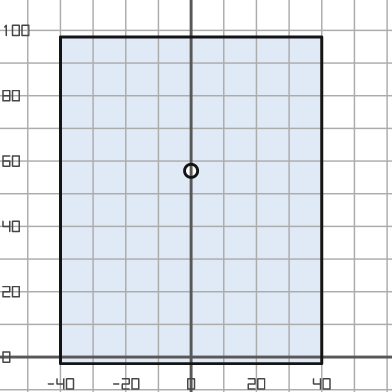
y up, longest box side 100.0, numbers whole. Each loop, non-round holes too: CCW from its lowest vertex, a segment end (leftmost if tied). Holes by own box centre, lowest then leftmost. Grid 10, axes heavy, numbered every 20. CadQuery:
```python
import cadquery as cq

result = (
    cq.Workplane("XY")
    .moveTo(-40.0, -2.0)
    .lineTo(40.0, -2.0)
    .lineTo(40.0, 98.0)
    .lineTo(-40.0, 98.0)
    .close()
    .moveTo(0.0, 57.0)
    .circle(2.0)
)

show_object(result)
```